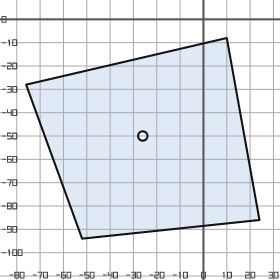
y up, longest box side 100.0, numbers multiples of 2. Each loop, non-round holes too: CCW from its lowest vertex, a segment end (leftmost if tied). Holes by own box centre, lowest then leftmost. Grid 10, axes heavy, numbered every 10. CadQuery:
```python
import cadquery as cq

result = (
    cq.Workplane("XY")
    .moveTo(-52.0, -94.0)
    .lineTo(24.0, -86.0)
    .lineTo(10.0, -8.0)
    .lineTo(-76.0, -28.0)
    .close()
    .moveTo(-26.0, -50.0)
    .circle(2.0)
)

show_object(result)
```